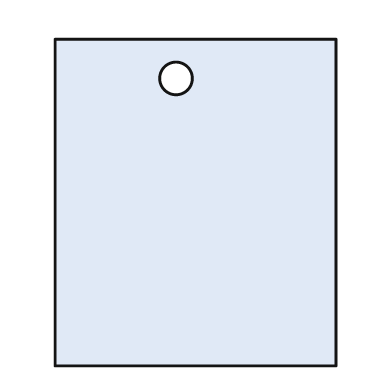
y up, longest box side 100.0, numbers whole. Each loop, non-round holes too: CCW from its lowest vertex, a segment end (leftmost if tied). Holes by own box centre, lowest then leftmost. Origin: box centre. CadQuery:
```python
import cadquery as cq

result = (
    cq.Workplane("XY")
    .moveTo(-43.0, -50.0)
    .lineTo(43.0, -50.0)
    .lineTo(43.0, 50.0)
    .lineTo(-43.0, 50.0)
    .close()
    .moveTo(-6.0, 38.0)
    .circle(5.0)
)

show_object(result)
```